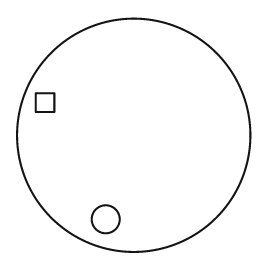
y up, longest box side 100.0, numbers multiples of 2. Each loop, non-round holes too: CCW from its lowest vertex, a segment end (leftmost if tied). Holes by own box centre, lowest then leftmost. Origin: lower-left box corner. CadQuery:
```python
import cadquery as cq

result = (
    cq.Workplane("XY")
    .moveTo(50.0, 50.0)
    .circle(50.0)
    .moveTo(38.0, 14.0)
    .circle(6.0)
    .moveTo(8.0, 60.0)
    .lineTo(16.0, 60.0)
    .lineTo(16.0, 68.0)
    .lineTo(8.0, 68.0)
    .close()
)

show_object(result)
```